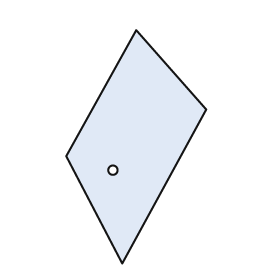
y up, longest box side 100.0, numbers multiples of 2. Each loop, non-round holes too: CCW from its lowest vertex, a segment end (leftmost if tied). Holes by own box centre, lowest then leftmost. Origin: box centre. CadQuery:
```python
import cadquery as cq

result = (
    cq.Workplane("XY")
    .moveTo(-6.0, -50.0)
    .lineTo(30.0, 16.0)
    .lineTo(0.0, 50.0)
    .lineTo(-30.0, -4.0)
    .close()
    .moveTo(-10.0, -10.0)
    .circle(2.0)
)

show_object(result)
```